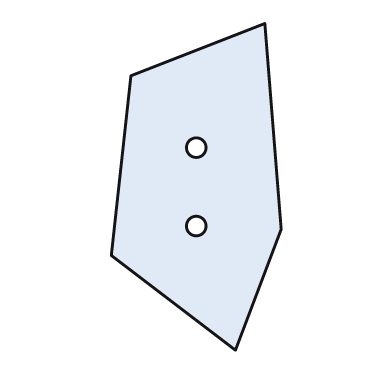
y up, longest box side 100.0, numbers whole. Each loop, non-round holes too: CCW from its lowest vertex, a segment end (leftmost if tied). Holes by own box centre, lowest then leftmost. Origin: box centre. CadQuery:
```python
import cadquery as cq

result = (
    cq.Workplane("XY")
    .moveTo(12.0, -50.0)
    .lineTo(26.0, -13.0)
    .lineTo(21.0, 50.0)
    .lineTo(-20.0, 34.0)
    .lineTo(-26.0, -21.0)
    .close()
    .moveTo(0.0, -12.0)
    .circle(3.0)
    .moveTo(0.0, 12.0)
    .circle(3.0)
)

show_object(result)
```